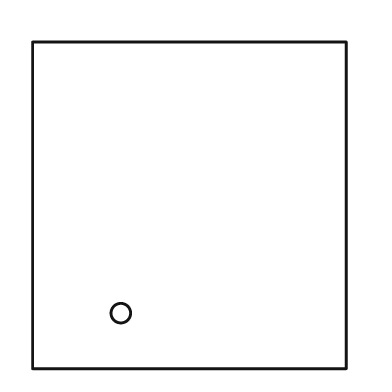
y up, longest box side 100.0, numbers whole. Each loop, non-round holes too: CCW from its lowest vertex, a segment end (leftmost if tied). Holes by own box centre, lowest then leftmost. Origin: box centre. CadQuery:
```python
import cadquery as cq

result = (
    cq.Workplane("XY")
    .moveTo(-48.0, -50.0)
    .lineTo(48.0, -50.0)
    .lineTo(48.0, 50.0)
    .lineTo(-48.0, 50.0)
    .close()
    .moveTo(-21.0, -33.0)
    .circle(3.0)
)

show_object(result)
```